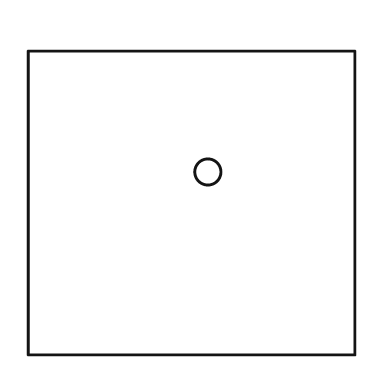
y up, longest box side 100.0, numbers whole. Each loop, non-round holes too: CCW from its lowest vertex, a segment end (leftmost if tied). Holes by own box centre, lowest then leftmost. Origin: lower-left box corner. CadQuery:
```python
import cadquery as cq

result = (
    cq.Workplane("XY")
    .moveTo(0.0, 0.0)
    .lineTo(100.0, 0.0)
    .lineTo(100.0, 93.0)
    .lineTo(0.0, 93.0)
    .close()
    .moveTo(55.0, 56.0)
    .circle(4.0)
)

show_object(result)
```